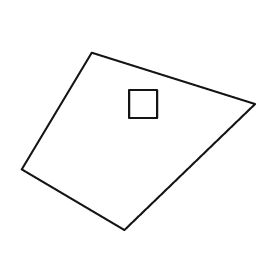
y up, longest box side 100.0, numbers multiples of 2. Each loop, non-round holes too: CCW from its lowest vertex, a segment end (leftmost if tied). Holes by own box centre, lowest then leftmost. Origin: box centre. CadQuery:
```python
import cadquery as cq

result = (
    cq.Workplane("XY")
    .moveTo(-6.0, -38.0)
    .lineTo(50.0, 16.0)
    .lineTo(-20.0, 38.0)
    .lineTo(-50.0, -12.0)
    .close()
    .moveTo(-4.0, 10.0)
    .lineTo(8.0, 10.0)
    .lineTo(8.0, 22.0)
    .lineTo(-4.0, 22.0)
    .close()
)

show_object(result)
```